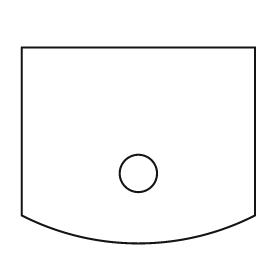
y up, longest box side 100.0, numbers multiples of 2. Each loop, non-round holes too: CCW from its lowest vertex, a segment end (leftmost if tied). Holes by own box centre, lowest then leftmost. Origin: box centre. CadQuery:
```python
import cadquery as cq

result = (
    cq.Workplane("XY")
    .moveTo(-50.0, -30.0)
    .threePointArc((0.0, -42.0), (50.0, -30.0))
    .lineTo(50.0, 42.0)
    .lineTo(-50.0, 42.0)
    .close()
    .moveTo(0.0, -12.0)
    .circle(8.0)
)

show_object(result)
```